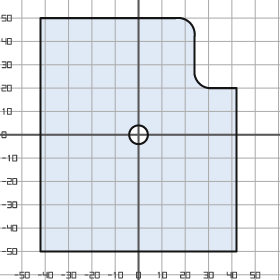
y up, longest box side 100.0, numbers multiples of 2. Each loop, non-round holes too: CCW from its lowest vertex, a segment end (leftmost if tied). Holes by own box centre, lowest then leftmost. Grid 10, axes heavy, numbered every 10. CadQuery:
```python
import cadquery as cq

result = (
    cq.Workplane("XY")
    .moveTo(-42.0, -50.0)
    .lineTo(42.0, -50.0)
    .lineTo(42.0, 20.0)
    .lineTo(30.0, 20.0)
    .threePointArc((26.0, 22.0), (24.0, 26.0))
    .lineTo(24.0, 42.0)
    .threePointArc((22.0, 48.0), (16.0, 50.0))
    .lineTo(-42.0, 50.0)
    .close()
    .moveTo(0.0, 0.0)
    .circle(4.0)
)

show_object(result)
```